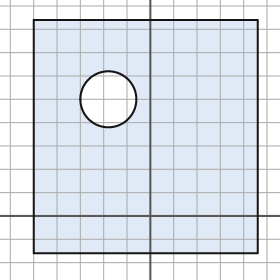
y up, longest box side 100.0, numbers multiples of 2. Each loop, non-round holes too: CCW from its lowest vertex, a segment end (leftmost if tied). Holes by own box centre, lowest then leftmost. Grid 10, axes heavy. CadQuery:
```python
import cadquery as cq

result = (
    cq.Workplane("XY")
    .moveTo(-50.0, -16.0)
    .lineTo(46.0, -16.0)
    .lineTo(46.0, 84.0)
    .lineTo(-50.0, 84.0)
    .close()
    .moveTo(-18.0, 50.0)
    .circle(12.0)
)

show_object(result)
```